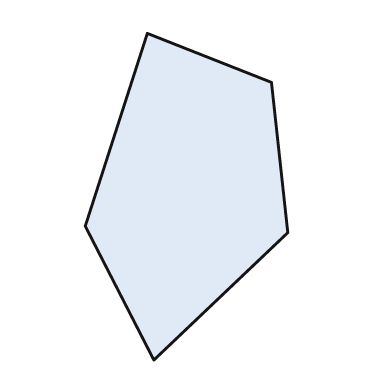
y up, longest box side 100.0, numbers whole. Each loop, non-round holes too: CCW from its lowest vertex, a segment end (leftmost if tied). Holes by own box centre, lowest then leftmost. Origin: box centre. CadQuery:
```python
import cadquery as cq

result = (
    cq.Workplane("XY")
    .moveTo(-10.0, -50.0)
    .lineTo(31.0, -11.0)
    .lineTo(26.0, 35.0)
    .lineTo(-12.0, 50.0)
    .lineTo(-31.0, -9.0)
    .close()
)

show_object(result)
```